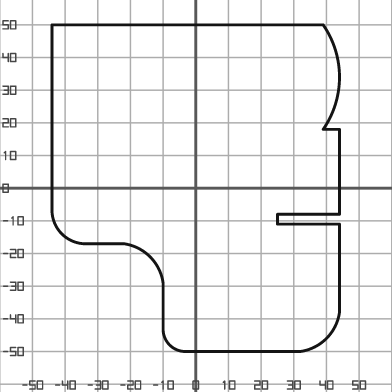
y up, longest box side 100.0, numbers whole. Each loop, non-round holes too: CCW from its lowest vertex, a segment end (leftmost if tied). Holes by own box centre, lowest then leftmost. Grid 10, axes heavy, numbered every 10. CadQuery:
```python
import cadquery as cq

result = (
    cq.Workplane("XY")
    .moveTo(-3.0, -50.0)
    .lineTo(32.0, -50.0)
    .threePointArc((40.0, -46.0), (44.0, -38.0))
    .lineTo(44.0, -11.0)
    .lineTo(25.0, -11.0)
    .lineTo(25.0, -8.0)
    .lineTo(44.0, -8.0)
    .lineTo(44.0, 18.0)
    .lineTo(39.0, 18.0)
    .threePointArc((44.0, 34.0), (39.0, 50.0))
    .lineTo(-44.0, 50.0)
    .lineTo(-44.0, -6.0)
    .threePointArc((-41.0, -14.0), (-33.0, -17.0))
    .lineTo(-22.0, -17.0)
    .threePointArc((-14.0, -21.0), (-10.0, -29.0))
    .lineTo(-10.0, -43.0)
    .threePointArc((-8.0, -48.0), (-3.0, -50.0))
    .close()
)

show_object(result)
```